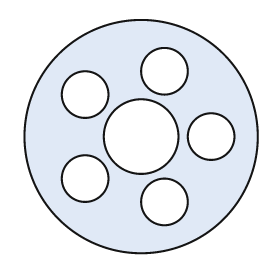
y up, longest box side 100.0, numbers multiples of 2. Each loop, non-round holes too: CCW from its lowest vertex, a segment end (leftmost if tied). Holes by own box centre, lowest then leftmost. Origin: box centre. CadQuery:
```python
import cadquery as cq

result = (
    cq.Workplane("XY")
    .moveTo(0.0, 0.0)
    .circle(50.0)
    .moveTo(10.0, -28.0)
    .circle(10.0)
    .moveTo(-24.0, -18.0)
    .circle(10.0)
    .moveTo(0.0, 0.0)
    .circle(16.0)
    .moveTo(30.0, 0.0)
    .circle(10.0)
    .moveTo(-24.0, 18.0)
    .circle(10.0)
    .moveTo(10.0, 28.0)
    .circle(10.0)
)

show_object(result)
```